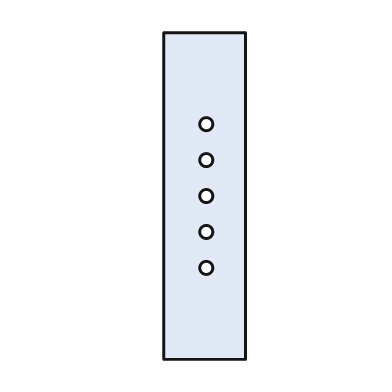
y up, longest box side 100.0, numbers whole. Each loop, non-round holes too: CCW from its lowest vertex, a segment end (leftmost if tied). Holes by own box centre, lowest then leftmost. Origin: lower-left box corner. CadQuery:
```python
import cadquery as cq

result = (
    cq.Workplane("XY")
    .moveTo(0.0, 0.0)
    .lineTo(25.0, 0.0)
    .lineTo(25.0, 100.0)
    .lineTo(0.0, 100.0)
    .close()
    .moveTo(13.0, 28.0)
    .circle(2.0)
    .moveTo(13.0, 39.0)
    .circle(2.0)
    .moveTo(13.0, 50.0)
    .circle(2.0)
    .moveTo(13.0, 61.0)
    .circle(2.0)
    .moveTo(13.0, 72.0)
    .circle(2.0)
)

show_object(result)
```